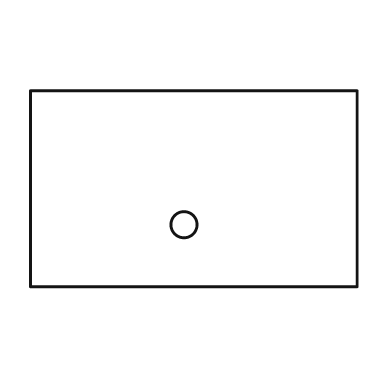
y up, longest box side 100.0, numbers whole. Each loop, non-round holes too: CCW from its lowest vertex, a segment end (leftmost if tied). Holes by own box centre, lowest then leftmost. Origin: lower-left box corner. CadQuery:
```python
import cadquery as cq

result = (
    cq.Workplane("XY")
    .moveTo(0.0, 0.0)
    .lineTo(100.0, 0.0)
    .lineTo(100.0, 60.0)
    .lineTo(0.0, 60.0)
    .close()
    .moveTo(47.0, 19.0)
    .circle(4.0)
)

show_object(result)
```